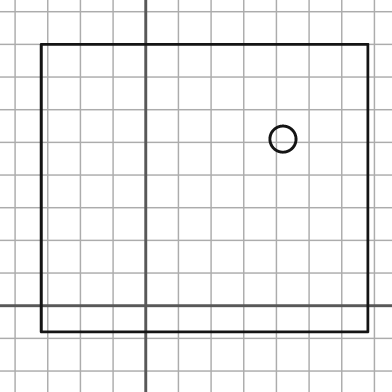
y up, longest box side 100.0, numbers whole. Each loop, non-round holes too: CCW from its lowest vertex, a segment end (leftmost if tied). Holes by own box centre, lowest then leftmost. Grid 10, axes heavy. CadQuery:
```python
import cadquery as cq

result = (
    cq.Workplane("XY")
    .moveTo(-32.0, -8.0)
    .lineTo(68.0, -8.0)
    .lineTo(68.0, 80.0)
    .lineTo(-32.0, 80.0)
    .close()
    .moveTo(42.0, 51.0)
    .circle(4.0)
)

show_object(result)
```